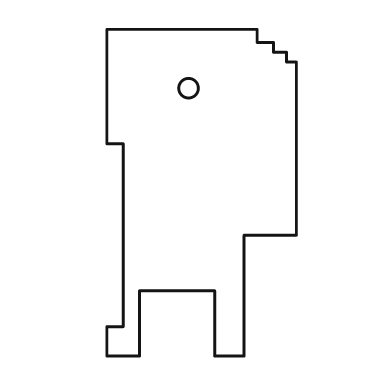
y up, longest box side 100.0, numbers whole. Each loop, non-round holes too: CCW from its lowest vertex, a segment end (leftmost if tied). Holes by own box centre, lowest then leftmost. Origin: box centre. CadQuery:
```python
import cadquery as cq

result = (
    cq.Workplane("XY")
    .moveTo(-29.0, -50.0)
    .lineTo(-19.0, -50.0)
    .lineTo(-19.0, -30.0)
    .lineTo(4.0, -30.0)
    .lineTo(4.0, -50.0)
    .lineTo(13.0, -50.0)
    .lineTo(13.0, -13.0)
    .lineTo(29.0, -13.0)
    .lineTo(29.0, 40.0)
    .lineTo(26.0, 40.0)
    .lineTo(26.0, 43.0)
    .lineTo(22.0, 43.0)
    .lineTo(22.0, 46.0)
    .lineTo(17.0, 46.0)
    .lineTo(17.0, 50.0)
    .lineTo(-29.0, 50.0)
    .lineTo(-29.0, 15.0)
    .lineTo(-24.0, 15.0)
    .lineTo(-24.0, -41.0)
    .lineTo(-29.0, -41.0)
    .close()
    .moveTo(-4.0, 32.0)
    .circle(3.0)
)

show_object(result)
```